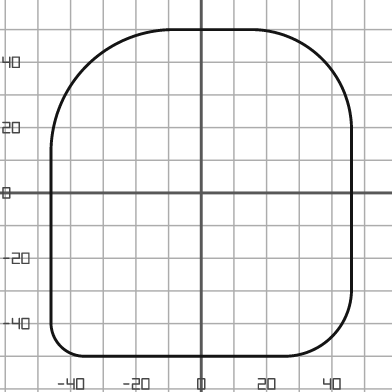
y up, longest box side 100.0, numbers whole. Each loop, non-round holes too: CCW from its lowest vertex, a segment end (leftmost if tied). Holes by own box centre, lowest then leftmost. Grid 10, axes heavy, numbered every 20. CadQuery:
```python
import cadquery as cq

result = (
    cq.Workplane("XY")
    .moveTo(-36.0, -50.0)
    .lineTo(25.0, -50.0)
    .threePointArc((40.0, -44.0), (46.0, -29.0))
    .lineTo(46.0, 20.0)
    .threePointArc((37.0, 41.0), (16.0, 50.0))
    .lineTo(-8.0, 50.0)
    .threePointArc((-35.0, 39.0), (-46.0, 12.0))
    .lineTo(-46.0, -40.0)
    .threePointArc((-43.0, -47.0), (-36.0, -50.0))
    .close()
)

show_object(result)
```